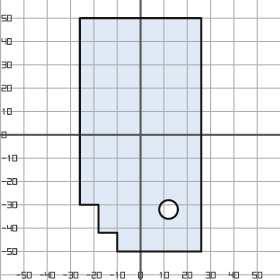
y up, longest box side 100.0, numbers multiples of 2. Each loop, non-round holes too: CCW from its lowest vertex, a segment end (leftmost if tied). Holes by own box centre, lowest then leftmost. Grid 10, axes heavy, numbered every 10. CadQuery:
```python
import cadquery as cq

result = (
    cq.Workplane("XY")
    .moveTo(-10.0, -50.0)
    .lineTo(26.0, -50.0)
    .lineTo(26.0, 50.0)
    .lineTo(-26.0, 50.0)
    .lineTo(-26.0, -30.0)
    .lineTo(-18.0, -30.0)
    .lineTo(-18.0, -42.0)
    .lineTo(-10.0, -42.0)
    .close()
    .moveTo(12.0, -32.0)
    .circle(4.0)
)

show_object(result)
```